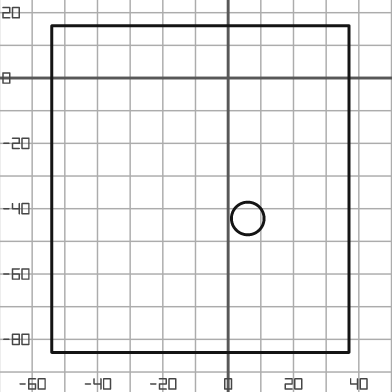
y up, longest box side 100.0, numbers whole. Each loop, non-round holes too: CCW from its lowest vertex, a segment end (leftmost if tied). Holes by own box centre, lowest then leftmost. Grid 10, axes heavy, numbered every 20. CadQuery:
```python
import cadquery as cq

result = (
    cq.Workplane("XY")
    .moveTo(-54.0, -84.0)
    .lineTo(37.0, -84.0)
    .lineTo(37.0, 16.0)
    .lineTo(-54.0, 16.0)
    .close()
    .moveTo(6.0, -43.0)
    .circle(5.0)
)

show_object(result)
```